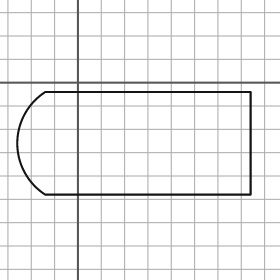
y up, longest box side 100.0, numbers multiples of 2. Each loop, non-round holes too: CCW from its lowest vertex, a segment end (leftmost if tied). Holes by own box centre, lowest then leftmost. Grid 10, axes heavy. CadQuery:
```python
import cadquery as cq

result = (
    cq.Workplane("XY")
    .moveTo(-14.0, -48.0)
    .lineTo(74.0, -48.0)
    .lineTo(74.0, -4.0)
    .lineTo(-14.0, -4.0)
    .threePointArc((-26.0, -26.0), (-14.0, -48.0))
    .close()
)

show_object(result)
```